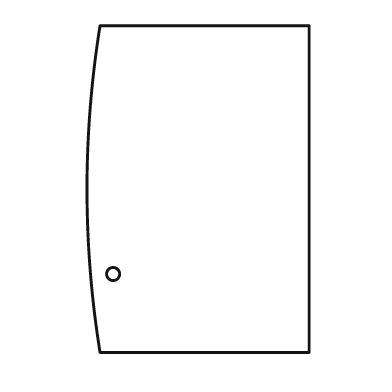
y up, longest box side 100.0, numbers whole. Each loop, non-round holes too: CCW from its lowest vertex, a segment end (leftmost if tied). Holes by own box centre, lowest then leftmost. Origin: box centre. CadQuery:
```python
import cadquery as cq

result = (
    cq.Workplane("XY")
    .moveTo(-30.0, -50.0)
    .lineTo(34.0, -50.0)
    .lineTo(34.0, 50.0)
    .lineTo(-30.0, 50.0)
    .threePointArc((-34.0, 0.0), (-30.0, -50.0))
    .close()
    .moveTo(-26.0, -26.0)
    .circle(2.0)
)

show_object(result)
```